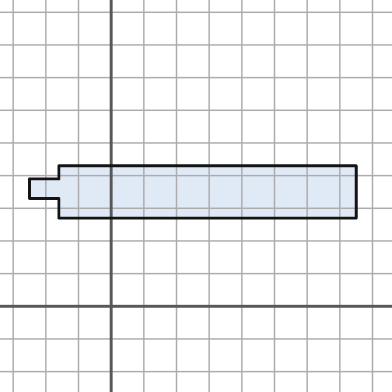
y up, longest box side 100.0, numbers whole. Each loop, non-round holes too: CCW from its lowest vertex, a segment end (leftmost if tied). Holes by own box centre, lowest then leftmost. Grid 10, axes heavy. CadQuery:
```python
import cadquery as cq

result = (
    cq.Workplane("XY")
    .moveTo(-16.0, 27.0)
    .lineTo(75.0, 27.0)
    .lineTo(75.0, 43.0)
    .lineTo(-16.0, 43.0)
    .lineTo(-16.0, 39.0)
    .lineTo(-25.0, 39.0)
    .lineTo(-25.0, 33.0)
    .lineTo(-16.0, 33.0)
    .close()
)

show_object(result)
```